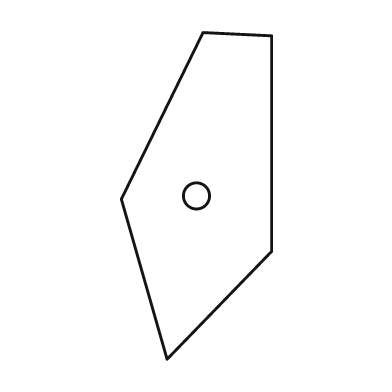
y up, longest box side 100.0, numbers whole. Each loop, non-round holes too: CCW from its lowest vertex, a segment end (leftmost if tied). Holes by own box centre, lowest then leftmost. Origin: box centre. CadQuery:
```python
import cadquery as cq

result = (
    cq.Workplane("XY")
    .moveTo(-9.0, -50.0)
    .lineTo(23.0, -17.0)
    .lineTo(23.0, 49.0)
    .lineTo(2.0, 50.0)
    .lineTo(-23.0, -1.0)
    .close()
    .moveTo(0.0, 0.0)
    .circle(4.0)
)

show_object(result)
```